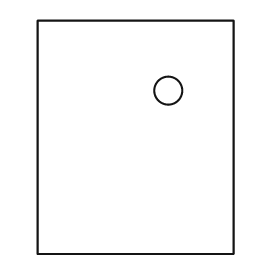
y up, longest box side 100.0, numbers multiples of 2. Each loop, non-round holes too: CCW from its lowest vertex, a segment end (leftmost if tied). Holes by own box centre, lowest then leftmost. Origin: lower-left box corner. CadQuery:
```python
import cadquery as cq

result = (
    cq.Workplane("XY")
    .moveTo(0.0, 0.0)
    .lineTo(84.0, 0.0)
    .lineTo(84.0, 100.0)
    .lineTo(0.0, 100.0)
    .close()
    .moveTo(56.0, 70.0)
    .circle(6.0)
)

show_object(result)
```